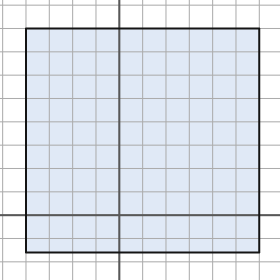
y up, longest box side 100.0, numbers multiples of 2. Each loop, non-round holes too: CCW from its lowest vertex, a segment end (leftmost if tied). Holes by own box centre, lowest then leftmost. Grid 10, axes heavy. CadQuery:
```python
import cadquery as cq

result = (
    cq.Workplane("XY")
    .moveTo(-40.0, -16.0)
    .lineTo(60.0, -16.0)
    .lineTo(60.0, 80.0)
    .lineTo(-40.0, 80.0)
    .close()
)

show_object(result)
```